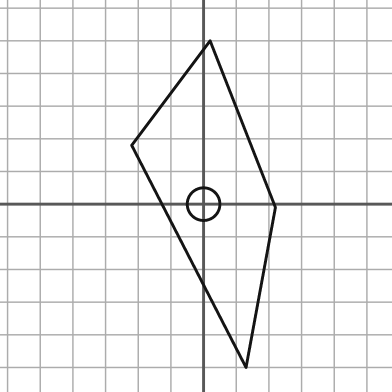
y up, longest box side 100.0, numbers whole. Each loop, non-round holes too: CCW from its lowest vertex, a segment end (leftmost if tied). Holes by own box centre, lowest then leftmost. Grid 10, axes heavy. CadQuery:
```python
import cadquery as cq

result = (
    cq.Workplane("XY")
    .moveTo(13.0, -50.0)
    .lineTo(22.0, -1.0)
    .lineTo(2.0, 50.0)
    .lineTo(-22.0, 18.0)
    .close()
    .moveTo(0.0, 0.0)
    .circle(5.0)
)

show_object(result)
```